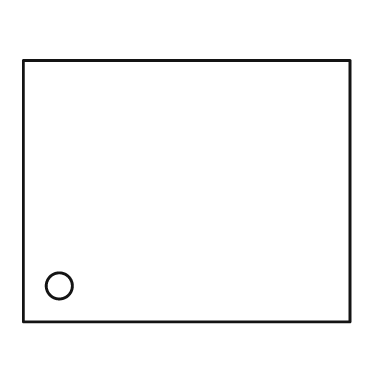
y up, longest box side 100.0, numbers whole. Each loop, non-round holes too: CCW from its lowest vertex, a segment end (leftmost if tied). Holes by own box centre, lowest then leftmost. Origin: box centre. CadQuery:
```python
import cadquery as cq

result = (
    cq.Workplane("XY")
    .moveTo(-50.0, -40.0)
    .lineTo(50.0, -40.0)
    .lineTo(50.0, 40.0)
    .lineTo(-50.0, 40.0)
    .close()
    .moveTo(-39.0, -29.0)
    .circle(4.0)
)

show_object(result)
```